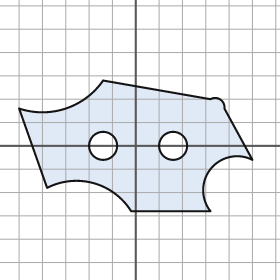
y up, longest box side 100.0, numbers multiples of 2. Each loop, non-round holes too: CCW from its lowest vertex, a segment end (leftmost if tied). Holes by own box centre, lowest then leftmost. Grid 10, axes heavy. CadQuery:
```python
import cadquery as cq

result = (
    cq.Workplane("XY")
    .moveTo(-2.0, -28.0)
    .lineTo(32.0, -28.0)
    .threePointArc((32.0, -10.0), (50.0, -6.0))
    .lineTo(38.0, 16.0)
    .threePointArc((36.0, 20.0), (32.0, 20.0))
    .lineTo(-14.0, 28.0)
    .threePointArc((-30.0, 16.0), (-50.0, 16.0))
    .lineTo(-38.0, -18.0)
    .threePointArc((-18.0, -16.0), (-2.0, -28.0))
    .close()
    .moveTo(-14.0, 0.0)
    .circle(6.0)
    .moveTo(16.0, 0.0)
    .circle(6.0)
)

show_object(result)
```